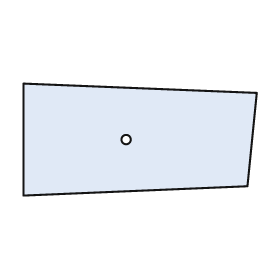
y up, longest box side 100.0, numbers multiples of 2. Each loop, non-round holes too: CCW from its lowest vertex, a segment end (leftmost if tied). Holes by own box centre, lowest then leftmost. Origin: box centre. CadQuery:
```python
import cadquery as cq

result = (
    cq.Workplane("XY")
    .moveTo(-50.0, -24.0)
    .lineTo(46.0, -20.0)
    .lineTo(50.0, 20.0)
    .lineTo(-50.0, 24.0)
    .close()
    .moveTo(-6.0, 0.0)
    .circle(2.0)
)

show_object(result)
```